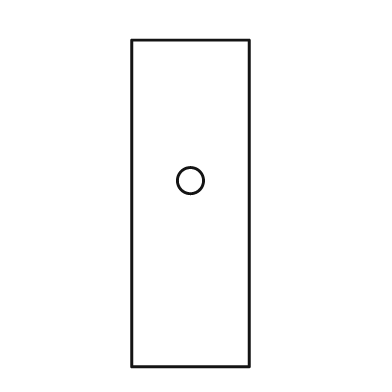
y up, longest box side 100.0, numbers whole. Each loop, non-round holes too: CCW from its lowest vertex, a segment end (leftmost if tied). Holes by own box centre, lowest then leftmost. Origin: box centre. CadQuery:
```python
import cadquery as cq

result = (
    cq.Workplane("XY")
    .moveTo(-18.0, -50.0)
    .lineTo(18.0, -50.0)
    .lineTo(18.0, 50.0)
    .lineTo(-18.0, 50.0)
    .close()
    .moveTo(0.0, 7.0)
    .circle(4.0)
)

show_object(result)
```